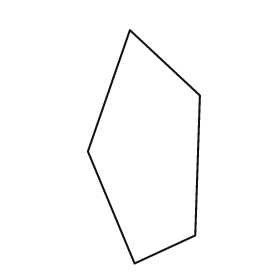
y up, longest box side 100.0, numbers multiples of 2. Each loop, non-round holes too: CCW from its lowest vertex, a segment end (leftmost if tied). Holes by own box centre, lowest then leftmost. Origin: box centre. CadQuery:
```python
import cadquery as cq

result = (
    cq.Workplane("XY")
    .moveTo(-4.0, -50.0)
    .lineTo(22.0, -38.0)
    .lineTo(24.0, 22.0)
    .lineTo(-6.0, 50.0)
    .lineTo(-24.0, -2.0)
    .close()
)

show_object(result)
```